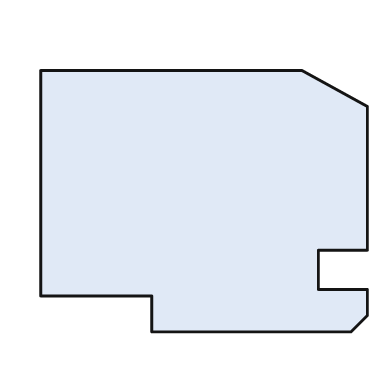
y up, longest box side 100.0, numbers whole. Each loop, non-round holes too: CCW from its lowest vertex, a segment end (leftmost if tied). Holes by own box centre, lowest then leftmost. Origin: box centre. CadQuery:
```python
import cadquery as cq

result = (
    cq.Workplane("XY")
    .moveTo(-16.0, -40.0)
    .lineTo(45.0, -40.0)
    .lineTo(50.0, -35.0)
    .lineTo(50.0, -27.0)
    .lineTo(35.0, -27.0)
    .lineTo(35.0, -15.0)
    .lineTo(50.0, -15.0)
    .lineTo(50.0, 29.0)
    .lineTo(30.0, 40.0)
    .lineTo(-50.0, 40.0)
    .lineTo(-50.0, -29.0)
    .lineTo(-16.0, -29.0)
    .close()
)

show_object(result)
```